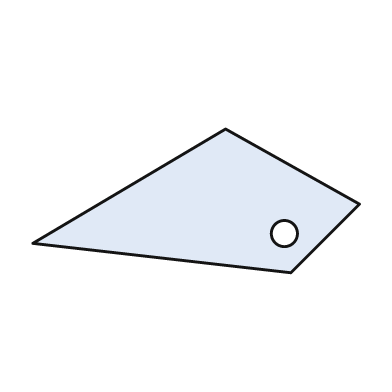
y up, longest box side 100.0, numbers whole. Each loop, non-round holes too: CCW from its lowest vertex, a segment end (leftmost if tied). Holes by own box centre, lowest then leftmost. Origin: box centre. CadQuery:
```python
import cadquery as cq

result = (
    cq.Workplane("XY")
    .moveTo(29.0, -22.0)
    .lineTo(50.0, -1.0)
    .lineTo(9.0, 22.0)
    .lineTo(-50.0, -13.0)
    .close()
    .moveTo(27.0, -10.0)
    .circle(4.0)
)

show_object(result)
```